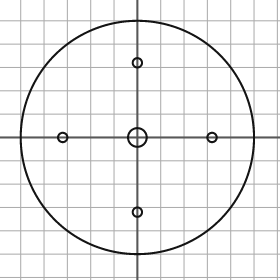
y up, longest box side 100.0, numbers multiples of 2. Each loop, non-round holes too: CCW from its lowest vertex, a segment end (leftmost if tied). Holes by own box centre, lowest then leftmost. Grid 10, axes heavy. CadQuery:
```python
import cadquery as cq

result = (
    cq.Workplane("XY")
    .moveTo(0.0, 0.0)
    .circle(50.0)
    .moveTo(0.0, -32.0)
    .circle(2.0)
    .moveTo(-32.0, 0.0)
    .circle(2.0)
    .moveTo(0.0, 0.0)
    .circle(4.0)
    .moveTo(32.0, 0.0)
    .circle(2.0)
    .moveTo(0.0, 32.0)
    .circle(2.0)
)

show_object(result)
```